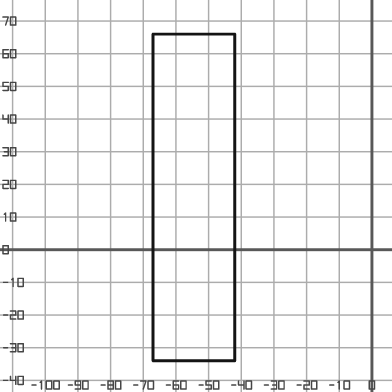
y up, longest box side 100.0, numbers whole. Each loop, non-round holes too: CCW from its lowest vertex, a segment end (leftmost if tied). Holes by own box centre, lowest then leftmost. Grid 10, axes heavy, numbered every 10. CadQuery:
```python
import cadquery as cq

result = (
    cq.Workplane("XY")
    .moveTo(-67.0, -34.0)
    .lineTo(-42.0, -34.0)
    .lineTo(-42.0, 66.0)
    .lineTo(-67.0, 66.0)
    .close()
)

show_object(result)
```